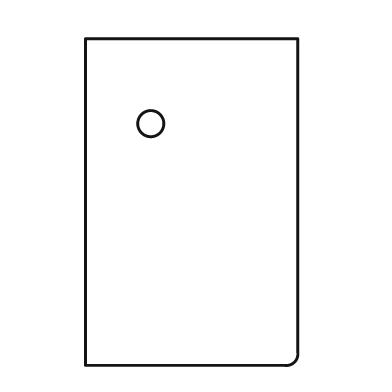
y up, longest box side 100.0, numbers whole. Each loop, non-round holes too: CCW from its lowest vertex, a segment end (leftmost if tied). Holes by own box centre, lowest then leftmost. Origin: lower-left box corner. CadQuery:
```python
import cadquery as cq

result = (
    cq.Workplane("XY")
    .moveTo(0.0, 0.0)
    .lineTo(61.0, 0.0)
    .threePointArc((64.0, 1.0), (65.0, 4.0))
    .lineTo(65.0, 100.0)
    .lineTo(0.0, 100.0)
    .close()
    .moveTo(20.0, 74.0)
    .circle(4.0)
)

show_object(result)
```